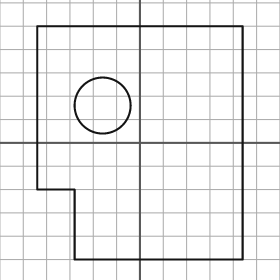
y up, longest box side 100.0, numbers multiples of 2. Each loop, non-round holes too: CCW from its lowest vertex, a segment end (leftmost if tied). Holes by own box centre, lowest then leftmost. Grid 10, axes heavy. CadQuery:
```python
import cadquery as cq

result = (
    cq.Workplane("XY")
    .moveTo(-28.0, -50.0)
    .lineTo(44.0, -50.0)
    .lineTo(44.0, 50.0)
    .lineTo(-44.0, 50.0)
    .lineTo(-44.0, -20.0)
    .lineTo(-28.0, -20.0)
    .close()
    .moveTo(-16.0, 16.0)
    .circle(12.0)
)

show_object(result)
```